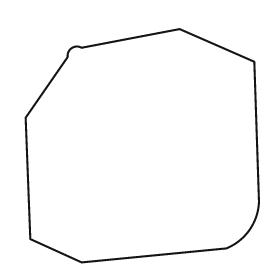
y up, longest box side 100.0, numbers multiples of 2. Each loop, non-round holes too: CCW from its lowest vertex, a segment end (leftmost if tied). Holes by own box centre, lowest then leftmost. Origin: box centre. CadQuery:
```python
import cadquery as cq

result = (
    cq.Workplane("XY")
    .moveTo(-26.0, -50.0)
    .lineTo(36.0, -44.0)
    .threePointArc((46.0, -36.0), (50.0, -24.0))
    .lineTo(48.0, 36.0)
    .lineTo(16.0, 50.0)
    .lineTo(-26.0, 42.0)
    .threePointArc((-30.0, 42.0), (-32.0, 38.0))
    .lineTo(-50.0, 12.0)
    .lineTo(-48.0, -40.0)
    .close()
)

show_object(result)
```